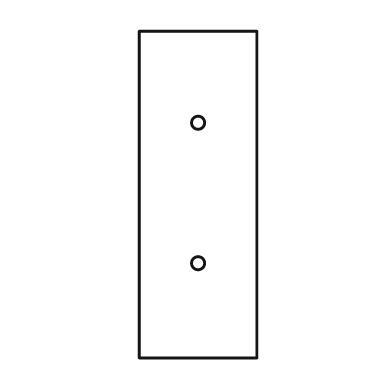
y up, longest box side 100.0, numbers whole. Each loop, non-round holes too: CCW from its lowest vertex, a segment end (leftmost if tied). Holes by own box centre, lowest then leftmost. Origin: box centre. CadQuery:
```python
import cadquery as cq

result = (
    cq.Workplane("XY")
    .moveTo(-18.0, -50.0)
    .lineTo(18.0, -50.0)
    .lineTo(18.0, 50.0)
    .lineTo(-18.0, 50.0)
    .close()
    .moveTo(0.0, -21.0)
    .circle(2.0)
    .moveTo(0.0, 22.0)
    .circle(2.0)
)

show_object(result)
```